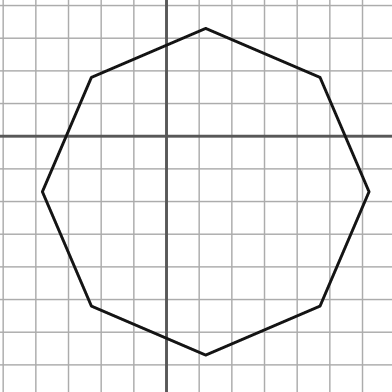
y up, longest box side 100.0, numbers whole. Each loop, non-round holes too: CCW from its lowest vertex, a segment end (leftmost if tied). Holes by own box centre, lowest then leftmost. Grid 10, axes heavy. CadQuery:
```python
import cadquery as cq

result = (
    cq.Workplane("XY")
    .moveTo(12.0, -67.0)
    .lineTo(47.0, -52.0)
    .lineTo(62.0, -17.0)
    .lineTo(47.0, 18.0)
    .lineTo(12.0, 33.0)
    .lineTo(-23.0, 18.0)
    .lineTo(-38.0, -17.0)
    .lineTo(-23.0, -52.0)
    .close()
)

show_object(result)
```